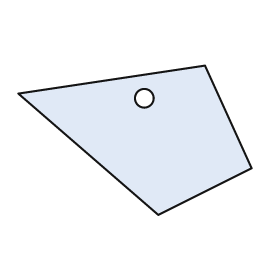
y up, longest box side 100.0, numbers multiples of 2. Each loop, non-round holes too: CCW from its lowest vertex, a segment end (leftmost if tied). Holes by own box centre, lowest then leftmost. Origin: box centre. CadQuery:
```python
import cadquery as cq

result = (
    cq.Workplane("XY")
    .moveTo(10.0, -32.0)
    .lineTo(50.0, -12.0)
    .lineTo(30.0, 32.0)
    .lineTo(-50.0, 20.0)
    .close()
    .moveTo(4.0, 18.0)
    .circle(4.0)
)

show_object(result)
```